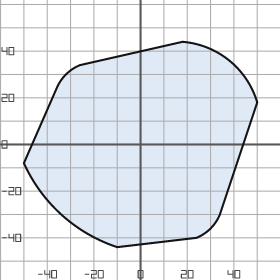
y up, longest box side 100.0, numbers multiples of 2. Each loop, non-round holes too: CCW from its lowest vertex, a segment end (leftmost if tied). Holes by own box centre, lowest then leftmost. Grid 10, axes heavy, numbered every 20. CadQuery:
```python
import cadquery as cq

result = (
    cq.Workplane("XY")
    .moveTo(-10.0, -44.0)
    .lineTo(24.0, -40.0)
    .threePointArc((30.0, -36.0), (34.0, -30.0))
    .lineTo(50.0, 18.0)
    .threePointArc((38.0, 36.0), (18.0, 44.0))
    .lineTo(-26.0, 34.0)
    .threePointArc((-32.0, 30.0), (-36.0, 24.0))
    .lineTo(-50.0, -8.0)
    .threePointArc((-34.0, -30.0), (-10.0, -44.0))
    .close()
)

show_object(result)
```